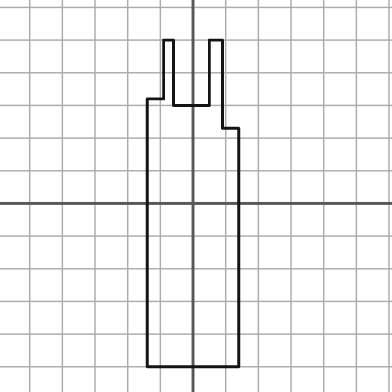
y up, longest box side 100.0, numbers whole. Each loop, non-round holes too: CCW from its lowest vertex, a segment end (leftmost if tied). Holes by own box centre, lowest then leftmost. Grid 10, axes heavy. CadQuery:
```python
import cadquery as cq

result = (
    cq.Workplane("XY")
    .moveTo(-14.0, -50.0)
    .lineTo(14.0, -50.0)
    .lineTo(14.0, 23.0)
    .lineTo(9.0, 23.0)
    .lineTo(9.0, 50.0)
    .lineTo(5.0, 50.0)
    .lineTo(5.0, 30.0)
    .lineTo(-6.0, 30.0)
    .lineTo(-6.0, 50.0)
    .lineTo(-9.0, 50.0)
    .lineTo(-9.0, 32.0)
    .lineTo(-14.0, 32.0)
    .close()
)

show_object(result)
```